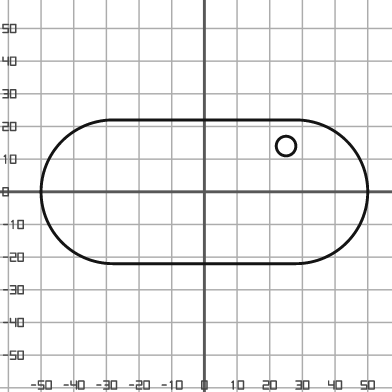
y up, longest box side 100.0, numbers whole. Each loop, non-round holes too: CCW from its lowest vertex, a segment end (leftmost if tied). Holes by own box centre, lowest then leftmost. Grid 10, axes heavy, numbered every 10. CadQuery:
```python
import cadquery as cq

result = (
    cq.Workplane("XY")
    .moveTo(-28.0, -22.0)
    .lineTo(28.0, -22.0)
    .threePointArc((50.0, 0.0), (28.0, 22.0))
    .lineTo(-28.0, 22.0)
    .threePointArc((-50.0, 0.0), (-28.0, -22.0))
    .close()
    .moveTo(25.0, 14.0)
    .circle(3.0)
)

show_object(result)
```